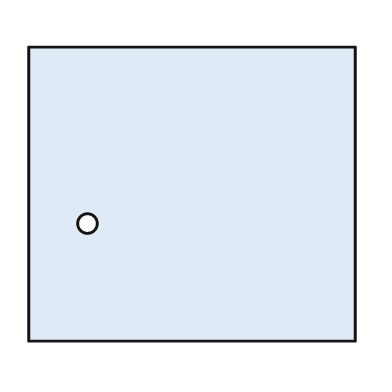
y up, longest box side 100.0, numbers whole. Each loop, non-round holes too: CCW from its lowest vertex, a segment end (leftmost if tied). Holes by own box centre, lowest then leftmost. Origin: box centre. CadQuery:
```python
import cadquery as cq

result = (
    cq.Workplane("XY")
    .moveTo(-50.0, -45.0)
    .lineTo(50.0, -45.0)
    .lineTo(50.0, 45.0)
    .lineTo(-50.0, 45.0)
    .close()
    .moveTo(-32.0, -9.0)
    .circle(3.0)
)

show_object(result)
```